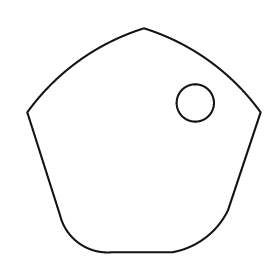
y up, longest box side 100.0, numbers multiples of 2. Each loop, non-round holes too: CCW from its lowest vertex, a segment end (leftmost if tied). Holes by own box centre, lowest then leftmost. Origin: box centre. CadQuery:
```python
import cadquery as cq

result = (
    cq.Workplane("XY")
    .moveTo(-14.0, -48.0)
    .lineTo(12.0, -48.0)
    .threePointArc((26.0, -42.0), (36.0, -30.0))
    .lineTo(50.0, 12.0)
    .threePointArc((28.0, 34.0), (0.0, 48.0))
    .threePointArc((-28.0, 34.0), (-50.0, 12.0))
    .lineTo(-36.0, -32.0)
    .threePointArc((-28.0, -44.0), (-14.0, -48.0))
    .close()
    .moveTo(22.0, 16.0)
    .circle(8.0)
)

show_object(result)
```